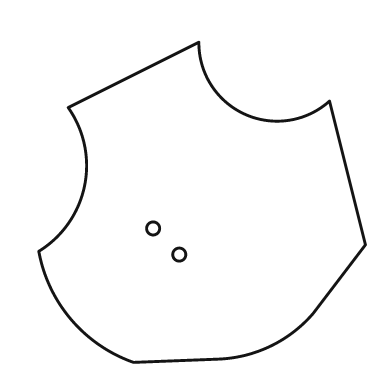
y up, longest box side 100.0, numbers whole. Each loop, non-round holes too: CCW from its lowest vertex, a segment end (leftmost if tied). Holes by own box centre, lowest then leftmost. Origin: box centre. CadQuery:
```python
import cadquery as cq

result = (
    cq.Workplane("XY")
    .moveTo(-21.0, -49.0)
    .lineTo(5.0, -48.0)
    .threePointArc((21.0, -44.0), (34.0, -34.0))
    .lineTo(50.0, -13.0)
    .lineTo(39.0, 31.0)
    .threePointArc((13.0, 27.0), (-1.0, 49.0))
    .lineTo(-41.0, 29.0)
    .threePointArc((-36.0, 5.0), (-50.0, -15.0))
    .threePointArc((-40.0, -36.0), (-21.0, -49.0))
    .close()
    .moveTo(-7.0, -16.0)
    .circle(2.0)
    .moveTo(-15.0, -8.0)
    .circle(2.0)
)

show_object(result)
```